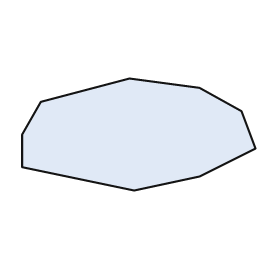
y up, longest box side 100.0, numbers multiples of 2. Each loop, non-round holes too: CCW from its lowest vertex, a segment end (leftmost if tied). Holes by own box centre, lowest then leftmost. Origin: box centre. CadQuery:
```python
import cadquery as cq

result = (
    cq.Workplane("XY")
    .moveTo(-2.0, -24.0)
    .lineTo(26.0, -18.0)
    .lineTo(50.0, -6.0)
    .lineTo(44.0, 10.0)
    .lineTo(26.0, 20.0)
    .lineTo(-4.0, 24.0)
    .lineTo(-42.0, 14.0)
    .lineTo(-50.0, 0.0)
    .lineTo(-50.0, -14.0)
    .close()
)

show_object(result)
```